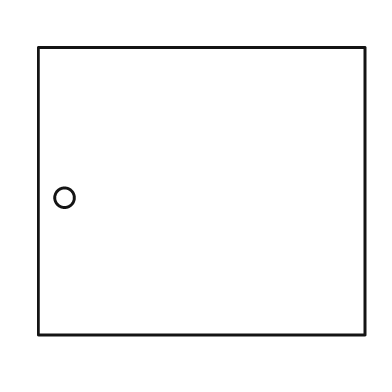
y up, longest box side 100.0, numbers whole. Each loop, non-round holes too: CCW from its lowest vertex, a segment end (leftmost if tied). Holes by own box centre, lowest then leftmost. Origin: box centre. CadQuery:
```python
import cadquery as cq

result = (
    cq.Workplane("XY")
    .moveTo(-50.0, -44.0)
    .lineTo(50.0, -44.0)
    .lineTo(50.0, 44.0)
    .lineTo(-50.0, 44.0)
    .close()
    .moveTo(-42.0, -2.0)
    .circle(3.0)
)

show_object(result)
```